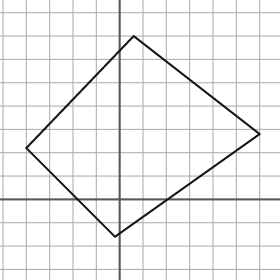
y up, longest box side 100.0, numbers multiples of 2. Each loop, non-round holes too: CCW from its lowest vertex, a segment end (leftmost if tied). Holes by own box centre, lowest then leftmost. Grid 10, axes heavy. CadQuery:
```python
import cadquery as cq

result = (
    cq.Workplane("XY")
    .moveTo(-2.0, -16.0)
    .lineTo(60.0, 28.0)
    .lineTo(6.0, 70.0)
    .lineTo(-40.0, 22.0)
    .close()
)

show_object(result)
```